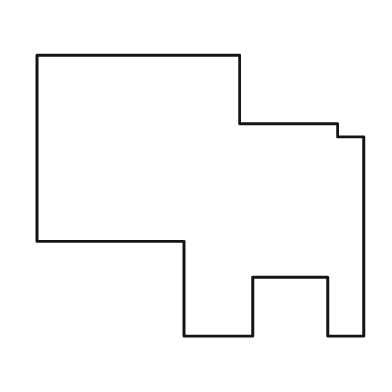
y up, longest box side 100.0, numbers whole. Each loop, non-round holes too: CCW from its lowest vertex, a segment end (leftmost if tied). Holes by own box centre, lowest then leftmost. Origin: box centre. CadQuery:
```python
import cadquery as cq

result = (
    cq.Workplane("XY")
    .moveTo(-5.0, -43.0)
    .lineTo(16.0, -43.0)
    .lineTo(16.0, -25.0)
    .lineTo(39.0, -25.0)
    .lineTo(39.0, -43.0)
    .lineTo(50.0, -43.0)
    .lineTo(50.0, 18.0)
    .lineTo(42.0, 18.0)
    .lineTo(42.0, 22.0)
    .lineTo(12.0, 22.0)
    .lineTo(12.0, 43.0)
    .lineTo(-50.0, 43.0)
    .lineTo(-50.0, -14.0)
    .lineTo(-5.0, -14.0)
    .close()
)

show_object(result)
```